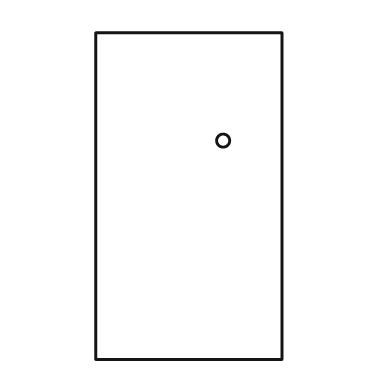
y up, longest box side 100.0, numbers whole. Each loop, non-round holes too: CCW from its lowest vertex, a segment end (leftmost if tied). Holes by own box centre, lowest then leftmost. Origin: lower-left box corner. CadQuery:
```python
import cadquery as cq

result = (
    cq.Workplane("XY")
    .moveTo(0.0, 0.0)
    .lineTo(57.0, 0.0)
    .lineTo(57.0, 100.0)
    .lineTo(0.0, 100.0)
    .close()
    .moveTo(39.0, 67.0)
    .circle(2.0)
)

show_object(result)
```